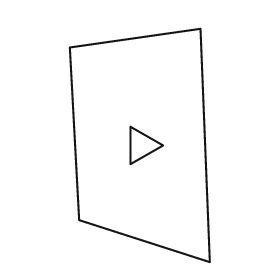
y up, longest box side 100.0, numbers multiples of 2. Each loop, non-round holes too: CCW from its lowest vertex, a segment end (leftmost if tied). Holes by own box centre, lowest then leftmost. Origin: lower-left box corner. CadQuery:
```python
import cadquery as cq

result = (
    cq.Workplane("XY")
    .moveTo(60.0, 0.0)
    .lineTo(56.0, 100.0)
    .lineTo(0.0, 92.0)
    .lineTo(4.0, 18.0)
    .close()
    .moveTo(26.0, 42.0)
    .lineTo(40.0, 50.0)
    .lineTo(26.0, 58.0)
    .close()
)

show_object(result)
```